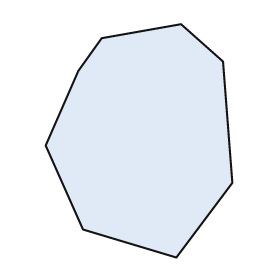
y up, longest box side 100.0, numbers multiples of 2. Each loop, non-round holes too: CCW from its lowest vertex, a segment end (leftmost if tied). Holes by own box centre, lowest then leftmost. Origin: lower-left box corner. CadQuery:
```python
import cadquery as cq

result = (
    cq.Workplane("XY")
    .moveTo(56.0, 0.0)
    .lineTo(80.0, 32.0)
    .lineTo(76.0, 84.0)
    .lineTo(58.0, 100.0)
    .lineTo(24.0, 94.0)
    .lineTo(14.0, 80.0)
    .lineTo(0.0, 48.0)
    .lineTo(16.0, 12.0)
    .close()
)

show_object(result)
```